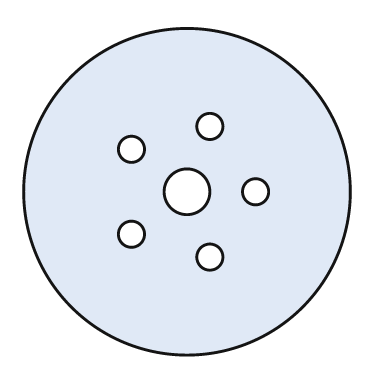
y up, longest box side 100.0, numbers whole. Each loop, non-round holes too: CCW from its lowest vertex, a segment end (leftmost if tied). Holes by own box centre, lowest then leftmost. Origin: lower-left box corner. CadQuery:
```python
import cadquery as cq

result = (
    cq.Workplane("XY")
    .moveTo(50.0, 50.0)
    .circle(50.0)
    .moveTo(57.0, 30.0)
    .circle(4.0)
    .moveTo(33.0, 37.0)
    .circle(4.0)
    .moveTo(50.0, 50.0)
    .circle(7.0)
    .moveTo(71.0, 50.0)
    .circle(4.0)
    .moveTo(33.0, 63.0)
    .circle(4.0)
    .moveTo(57.0, 70.0)
    .circle(4.0)
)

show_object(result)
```